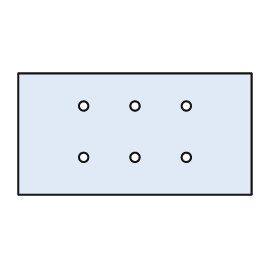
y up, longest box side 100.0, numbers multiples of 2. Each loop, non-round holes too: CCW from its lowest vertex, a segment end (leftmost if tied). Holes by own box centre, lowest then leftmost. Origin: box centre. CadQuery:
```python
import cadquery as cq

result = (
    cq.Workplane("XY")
    .moveTo(-50.0, -26.0)
    .lineTo(50.0, -26.0)
    .lineTo(50.0, 26.0)
    .lineTo(-50.0, 26.0)
    .close()
    .moveTo(-22.0, -10.0)
    .circle(2.0)
    .moveTo(0.0, -10.0)
    .circle(2.0)
    .moveTo(22.0, -10.0)
    .circle(2.0)
    .moveTo(-22.0, 12.0)
    .circle(2.0)
    .moveTo(0.0, 12.0)
    .circle(2.0)
    .moveTo(22.0, 12.0)
    .circle(2.0)
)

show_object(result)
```